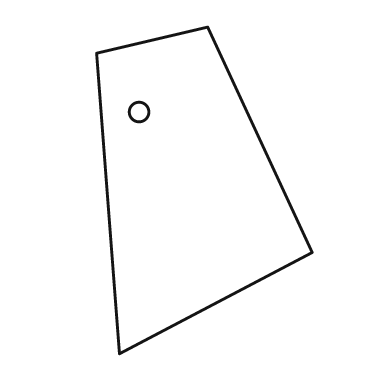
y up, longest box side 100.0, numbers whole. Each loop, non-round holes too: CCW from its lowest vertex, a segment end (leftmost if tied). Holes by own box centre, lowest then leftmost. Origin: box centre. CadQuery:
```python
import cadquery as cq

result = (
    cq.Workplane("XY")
    .moveTo(-26.0, -50.0)
    .lineTo(33.0, -19.0)
    .lineTo(1.0, 50.0)
    .lineTo(-33.0, 42.0)
    .close()
    .moveTo(-20.0, 24.0)
    .circle(3.0)
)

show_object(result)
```